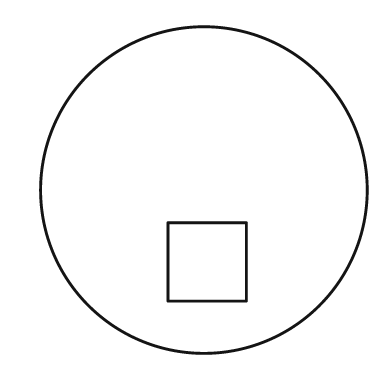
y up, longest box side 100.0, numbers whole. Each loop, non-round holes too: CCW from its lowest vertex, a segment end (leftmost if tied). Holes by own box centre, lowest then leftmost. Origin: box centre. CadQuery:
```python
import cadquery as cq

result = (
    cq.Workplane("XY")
    .moveTo(0.0, 0.0)
    .circle(50.0)
    .moveTo(-11.0, -34.0)
    .lineTo(13.0, -34.0)
    .lineTo(13.0, -10.0)
    .lineTo(-11.0, -10.0)
    .close()
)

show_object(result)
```